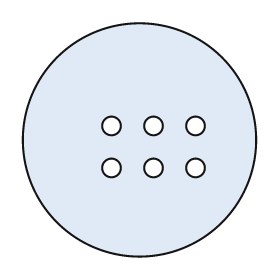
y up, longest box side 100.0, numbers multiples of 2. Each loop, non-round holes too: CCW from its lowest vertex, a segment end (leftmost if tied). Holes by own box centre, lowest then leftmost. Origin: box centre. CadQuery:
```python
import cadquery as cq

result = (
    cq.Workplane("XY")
    .moveTo(0.0, 0.0)
    .circle(50.0)
    .moveTo(-12.0, -12.0)
    .circle(4.0)
    .moveTo(6.0, -12.0)
    .circle(4.0)
    .moveTo(24.0, -12.0)
    .circle(4.0)
    .moveTo(-12.0, 6.0)
    .circle(4.0)
    .moveTo(6.0, 6.0)
    .circle(4.0)
    .moveTo(24.0, 6.0)
    .circle(4.0)
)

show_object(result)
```